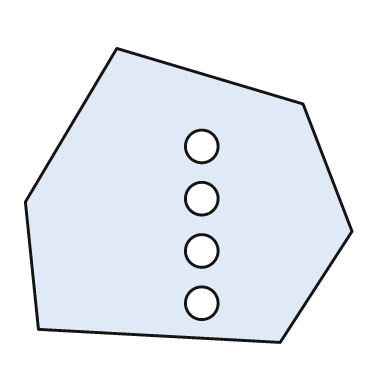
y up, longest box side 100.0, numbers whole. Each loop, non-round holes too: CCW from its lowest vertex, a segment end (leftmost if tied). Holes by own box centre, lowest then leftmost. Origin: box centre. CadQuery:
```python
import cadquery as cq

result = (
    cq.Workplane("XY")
    .moveTo(28.0, -45.0)
    .lineTo(50.0, -11.0)
    .lineTo(35.0, 28.0)
    .lineTo(-22.0, 45.0)
    .lineTo(-50.0, -2.0)
    .lineTo(-46.0, -41.0)
    .close()
    .moveTo(4.0, -33.0)
    .circle(5.0)
    .moveTo(4.0, -17.0)
    .circle(5.0)
    .moveTo(4.0, -1.0)
    .circle(5.0)
    .moveTo(4.0, 15.0)
    .circle(5.0)
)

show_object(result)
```